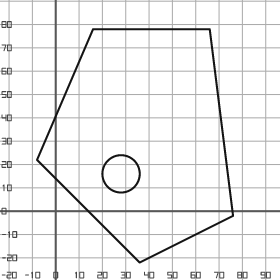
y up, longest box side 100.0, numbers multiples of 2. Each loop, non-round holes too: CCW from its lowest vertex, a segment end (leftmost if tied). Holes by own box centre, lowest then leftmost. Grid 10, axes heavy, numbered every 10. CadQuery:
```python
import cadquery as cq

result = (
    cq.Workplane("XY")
    .moveTo(36.0, -22.0)
    .lineTo(76.0, -2.0)
    .lineTo(66.0, 78.0)
    .lineTo(16.0, 78.0)
    .lineTo(-8.0, 22.0)
    .close()
    .moveTo(28.0, 16.0)
    .circle(8.0)
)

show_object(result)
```